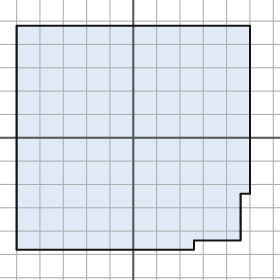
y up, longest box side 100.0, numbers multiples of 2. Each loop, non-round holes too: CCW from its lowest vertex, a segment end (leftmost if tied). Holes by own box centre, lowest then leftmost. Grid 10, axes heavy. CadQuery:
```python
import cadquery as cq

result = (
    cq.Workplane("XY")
    .moveTo(-50.0, -48.0)
    .lineTo(26.0, -48.0)
    .lineTo(26.0, -44.0)
    .lineTo(46.0, -44.0)
    .lineTo(46.0, -24.0)
    .lineTo(50.0, -24.0)
    .lineTo(50.0, 48.0)
    .lineTo(-50.0, 48.0)
    .close()
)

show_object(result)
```